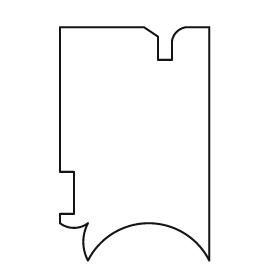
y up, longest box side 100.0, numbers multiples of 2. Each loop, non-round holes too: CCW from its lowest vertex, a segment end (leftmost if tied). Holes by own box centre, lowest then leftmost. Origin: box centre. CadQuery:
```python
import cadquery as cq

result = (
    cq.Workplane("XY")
    .moveTo(-20.0, -50.0)
    .threePointArc((6.0, -34.0), (32.0, -50.0))
    .lineTo(32.0, 50.0)
    .lineTo(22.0, 50.0)
    .threePointArc((18.0, 48.0), (16.0, 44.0))
    .lineTo(16.0, 36.0)
    .lineTo(10.0, 36.0)
    .lineTo(10.0, 46.0)
    .lineTo(4.0, 50.0)
    .lineTo(-32.0, 50.0)
    .lineTo(-32.0, -12.0)
    .lineTo(-26.0, -12.0)
    .lineTo(-26.0, -30.0)
    .lineTo(-32.0, -30.0)
    .lineTo(-32.0, -34.0)
    .threePointArc((-26.0, -36.0), (-20.0, -34.0))
    .threePointArc((-22.0, -42.0), (-20.0, -50.0))
    .close()
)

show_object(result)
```